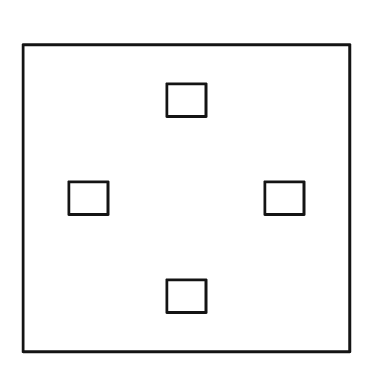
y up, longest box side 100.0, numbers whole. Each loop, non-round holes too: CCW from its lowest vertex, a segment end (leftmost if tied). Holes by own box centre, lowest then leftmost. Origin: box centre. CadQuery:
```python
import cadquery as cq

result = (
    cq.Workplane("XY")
    .moveTo(-50.0, -47.0)
    .lineTo(50.0, -47.0)
    .lineTo(50.0, 47.0)
    .lineTo(-50.0, 47.0)
    .close()
    .moveTo(-6.0, -35.0)
    .lineTo(6.0, -35.0)
    .lineTo(6.0, -25.0)
    .lineTo(-6.0, -25.0)
    .close()
    .moveTo(-36.0, -5.0)
    .lineTo(-24.0, -5.0)
    .lineTo(-24.0, 5.0)
    .lineTo(-36.0, 5.0)
    .close()
    .moveTo(24.0, -5.0)
    .lineTo(36.0, -5.0)
    .lineTo(36.0, 5.0)
    .lineTo(24.0, 5.0)
    .close()
    .moveTo(-6.0, 25.0)
    .lineTo(6.0, 25.0)
    .lineTo(6.0, 35.0)
    .lineTo(-6.0, 35.0)
    .close()
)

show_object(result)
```